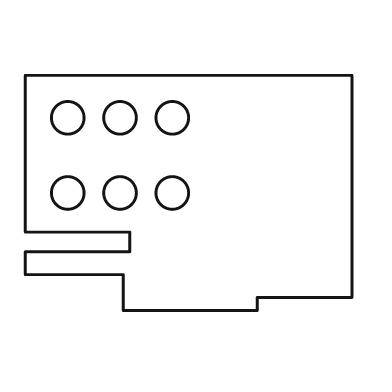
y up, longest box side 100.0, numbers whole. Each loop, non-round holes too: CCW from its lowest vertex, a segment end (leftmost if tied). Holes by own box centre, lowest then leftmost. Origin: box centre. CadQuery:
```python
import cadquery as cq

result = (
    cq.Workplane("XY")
    .moveTo(-20.0, -36.0)
    .lineTo(21.0, -36.0)
    .lineTo(21.0, -32.0)
    .lineTo(50.0, -32.0)
    .lineTo(50.0, 36.0)
    .lineTo(-50.0, 36.0)
    .lineTo(-50.0, -12.0)
    .lineTo(-18.0, -12.0)
    .lineTo(-18.0, -18.0)
    .lineTo(-50.0, -18.0)
    .lineTo(-50.0, -25.0)
    .lineTo(-20.0, -25.0)
    .close()
    .moveTo(-37.0, 0.0)
    .circle(5.0)
    .moveTo(-21.0, 0.0)
    .circle(5.0)
    .moveTo(-5.0, 0.0)
    .circle(5.0)
    .moveTo(-37.0, 23.0)
    .circle(5.0)
    .moveTo(-21.0, 23.0)
    .circle(5.0)
    .moveTo(-5.0, 23.0)
    .circle(5.0)
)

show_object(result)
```